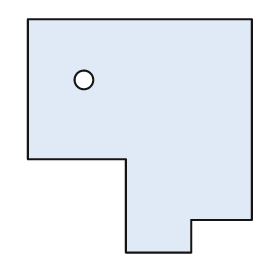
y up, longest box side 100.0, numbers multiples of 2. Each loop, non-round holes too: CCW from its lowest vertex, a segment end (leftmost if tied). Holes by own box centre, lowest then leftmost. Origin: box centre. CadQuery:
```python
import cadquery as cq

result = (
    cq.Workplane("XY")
    .moveTo(-6.0, -50.0)
    .lineTo(22.0, -50.0)
    .lineTo(22.0, -36.0)
    .lineTo(48.0, -36.0)
    .lineTo(48.0, 50.0)
    .lineTo(-48.0, 50.0)
    .lineTo(-48.0, -10.0)
    .lineTo(-6.0, -10.0)
    .close()
    .moveTo(-24.0, 24.0)
    .circle(4.0)
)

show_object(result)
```